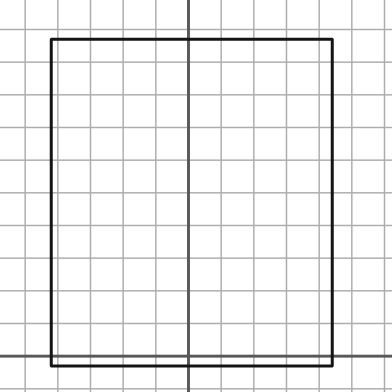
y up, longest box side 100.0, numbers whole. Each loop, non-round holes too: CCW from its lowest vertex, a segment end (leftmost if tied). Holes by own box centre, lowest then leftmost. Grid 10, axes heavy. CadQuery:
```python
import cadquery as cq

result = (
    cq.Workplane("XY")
    .moveTo(-42.0, -3.0)
    .lineTo(44.0, -3.0)
    .lineTo(44.0, 97.0)
    .lineTo(-42.0, 97.0)
    .close()
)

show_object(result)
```